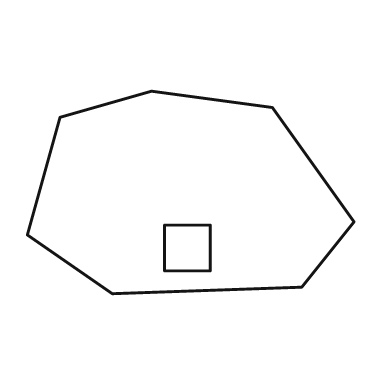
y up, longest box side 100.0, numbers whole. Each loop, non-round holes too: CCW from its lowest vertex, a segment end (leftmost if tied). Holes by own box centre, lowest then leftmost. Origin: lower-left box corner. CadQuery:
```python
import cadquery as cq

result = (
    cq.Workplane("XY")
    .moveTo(26.0, 0.0)
    .lineTo(84.0, 2.0)
    .lineTo(100.0, 22.0)
    .lineTo(75.0, 57.0)
    .lineTo(38.0, 62.0)
    .lineTo(10.0, 54.0)
    .lineTo(0.0, 18.0)
    .close()
    .moveTo(42.0, 7.0)
    .lineTo(56.0, 7.0)
    .lineTo(56.0, 21.0)
    .lineTo(42.0, 21.0)
    .close()
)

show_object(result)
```